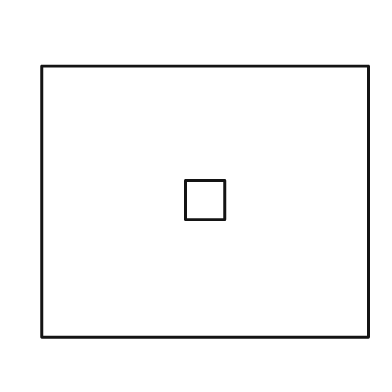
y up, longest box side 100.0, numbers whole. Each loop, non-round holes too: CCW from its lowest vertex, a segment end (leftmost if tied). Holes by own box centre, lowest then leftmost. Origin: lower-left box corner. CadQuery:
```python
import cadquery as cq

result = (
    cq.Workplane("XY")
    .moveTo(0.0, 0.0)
    .lineTo(100.0, 0.0)
    .lineTo(100.0, 83.0)
    .lineTo(0.0, 83.0)
    .close()
    .moveTo(44.0, 36.0)
    .lineTo(56.0, 36.0)
    .lineTo(56.0, 48.0)
    .lineTo(44.0, 48.0)
    .close()
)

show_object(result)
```